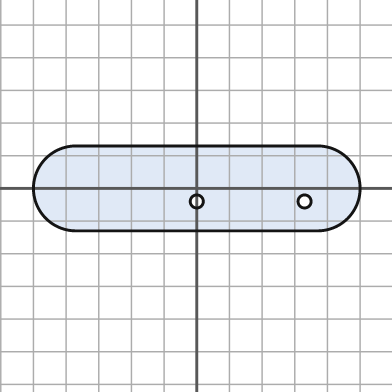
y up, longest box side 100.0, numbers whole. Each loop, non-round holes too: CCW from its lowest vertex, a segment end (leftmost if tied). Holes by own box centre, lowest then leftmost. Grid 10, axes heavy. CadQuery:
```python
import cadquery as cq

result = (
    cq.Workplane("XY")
    .moveTo(-37.0, -13.0)
    .lineTo(37.0, -13.0)
    .threePointArc((50.0, 0.0), (37.0, 13.0))
    .lineTo(-37.0, 13.0)
    .threePointArc((-50.0, 0.0), (-37.0, -13.0))
    .close()
    .moveTo(0.0, -4.0)
    .circle(2.0)
    .moveTo(33.0, -4.0)
    .circle(2.0)
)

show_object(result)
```